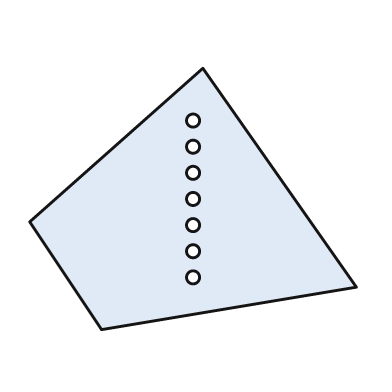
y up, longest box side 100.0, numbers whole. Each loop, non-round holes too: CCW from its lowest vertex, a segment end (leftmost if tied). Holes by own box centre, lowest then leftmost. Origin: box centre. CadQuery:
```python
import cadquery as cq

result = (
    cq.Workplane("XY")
    .moveTo(-28.0, -40.0)
    .lineTo(50.0, -27.0)
    .lineTo(3.0, 40.0)
    .lineTo(-50.0, -7.0)
    .close()
    .moveTo(0.0, -24.0)
    .circle(2.0)
    .moveTo(0.0, -16.0)
    .circle(2.0)
    .moveTo(0.0, -8.0)
    .circle(2.0)
    .moveTo(0.0, 0.0)
    .circle(2.0)
    .moveTo(0.0, 8.0)
    .circle(2.0)
    .moveTo(0.0, 16.0)
    .circle(2.0)
    .moveTo(0.0, 24.0)
    .circle(2.0)
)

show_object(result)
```